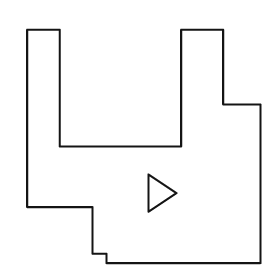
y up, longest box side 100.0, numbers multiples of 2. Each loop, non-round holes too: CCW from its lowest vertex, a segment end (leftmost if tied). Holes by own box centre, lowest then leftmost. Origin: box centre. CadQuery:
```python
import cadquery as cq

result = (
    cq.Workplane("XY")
    .moveTo(-16.0, -50.0)
    .lineTo(50.0, -50.0)
    .lineTo(50.0, 18.0)
    .lineTo(34.0, 18.0)
    .lineTo(34.0, 50.0)
    .lineTo(16.0, 50.0)
    .lineTo(16.0, 0.0)
    .lineTo(-36.0, 0.0)
    .lineTo(-36.0, 50.0)
    .lineTo(-50.0, 50.0)
    .lineTo(-50.0, -26.0)
    .lineTo(-22.0, -26.0)
    .lineTo(-22.0, -46.0)
    .lineTo(-16.0, -46.0)
    .close()
    .moveTo(2.0, -28.0)
    .lineTo(14.0, -20.0)
    .lineTo(2.0, -12.0)
    .close()
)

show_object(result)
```